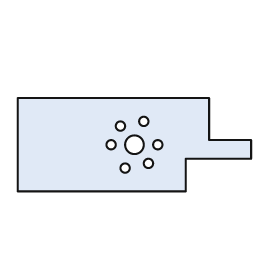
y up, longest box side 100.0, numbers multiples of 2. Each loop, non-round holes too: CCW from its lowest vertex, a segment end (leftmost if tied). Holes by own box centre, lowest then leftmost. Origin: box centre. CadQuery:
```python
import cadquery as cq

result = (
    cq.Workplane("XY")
    .moveTo(-50.0, -20.0)
    .lineTo(22.0, -20.0)
    .lineTo(22.0, -6.0)
    .lineTo(50.0, -6.0)
    .lineTo(50.0, 2.0)
    .lineTo(32.0, 2.0)
    .lineTo(32.0, 20.0)
    .lineTo(-50.0, 20.0)
    .close()
    .moveTo(-4.0, -10.0)
    .circle(2.0)
    .moveTo(6.0, -8.0)
    .circle(2.0)
    .moveTo(-10.0, 0.0)
    .circle(2.0)
    .moveTo(0.0, 0.0)
    .circle(4.0)
    .moveTo(10.0, 0.0)
    .circle(2.0)
    .moveTo(-6.0, 8.0)
    .circle(2.0)
    .moveTo(4.0, 10.0)
    .circle(2.0)
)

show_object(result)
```